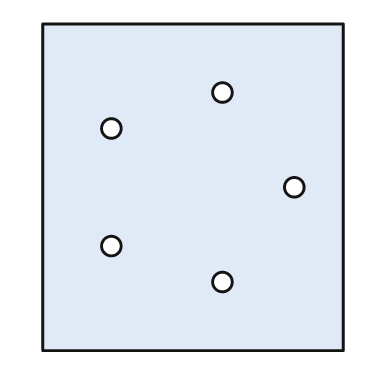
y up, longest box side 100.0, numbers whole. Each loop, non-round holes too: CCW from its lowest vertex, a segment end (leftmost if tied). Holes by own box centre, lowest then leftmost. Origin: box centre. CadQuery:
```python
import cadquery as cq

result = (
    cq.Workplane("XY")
    .moveTo(-46.0, -50.0)
    .lineTo(46.0, -50.0)
    .lineTo(46.0, 50.0)
    .lineTo(-46.0, 50.0)
    .close()
    .moveTo(9.0, -29.0)
    .circle(3.0)
    .moveTo(-25.0, -18.0)
    .circle(3.0)
    .moveTo(31.0, 0.0)
    .circle(3.0)
    .moveTo(-25.0, 18.0)
    .circle(3.0)
    .moveTo(9.0, 29.0)
    .circle(3.0)
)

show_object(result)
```